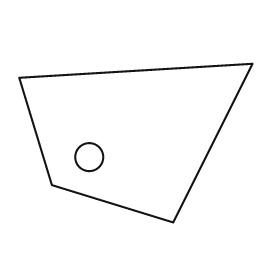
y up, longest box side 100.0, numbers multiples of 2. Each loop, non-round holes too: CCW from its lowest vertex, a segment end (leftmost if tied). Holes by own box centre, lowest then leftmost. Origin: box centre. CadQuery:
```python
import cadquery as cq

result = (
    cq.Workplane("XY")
    .moveTo(16.0, -34.0)
    .lineTo(50.0, 34.0)
    .lineTo(-50.0, 28.0)
    .lineTo(-36.0, -18.0)
    .close()
    .moveTo(-20.0, -6.0)
    .circle(6.0)
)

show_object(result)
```